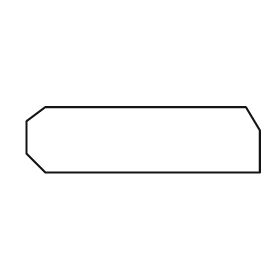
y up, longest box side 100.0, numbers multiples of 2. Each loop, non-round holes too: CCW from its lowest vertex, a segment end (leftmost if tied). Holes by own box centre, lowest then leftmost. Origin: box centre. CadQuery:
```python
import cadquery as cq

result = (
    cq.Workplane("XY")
    .moveTo(-42.0, -14.0)
    .lineTo(50.0, -14.0)
    .lineTo(50.0, 4.0)
    .lineTo(44.0, 14.0)
    .lineTo(-42.0, 14.0)
    .lineTo(-50.0, 8.0)
    .lineTo(-50.0, -6.0)
    .close()
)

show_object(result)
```